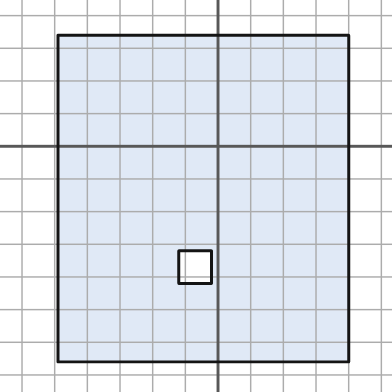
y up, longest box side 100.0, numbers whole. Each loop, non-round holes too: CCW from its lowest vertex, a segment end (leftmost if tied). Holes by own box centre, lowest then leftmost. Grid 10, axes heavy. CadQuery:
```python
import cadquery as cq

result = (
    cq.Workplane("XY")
    .moveTo(-49.0, -66.0)
    .lineTo(40.0, -66.0)
    .lineTo(40.0, 34.0)
    .lineTo(-49.0, 34.0)
    .close()
    .moveTo(-12.0, -42.0)
    .lineTo(-2.0, -42.0)
    .lineTo(-2.0, -32.0)
    .lineTo(-12.0, -32.0)
    .close()
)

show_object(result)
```